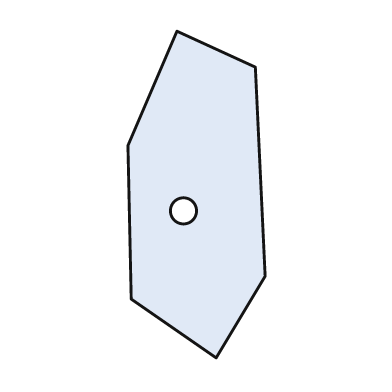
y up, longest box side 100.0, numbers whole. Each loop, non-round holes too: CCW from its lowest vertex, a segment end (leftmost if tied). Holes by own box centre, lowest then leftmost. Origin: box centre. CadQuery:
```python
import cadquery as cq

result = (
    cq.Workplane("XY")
    .moveTo(6.0, -50.0)
    .lineTo(21.0, -25.0)
    .lineTo(18.0, 39.0)
    .lineTo(-6.0, 50.0)
    .lineTo(-21.0, 15.0)
    .lineTo(-20.0, -32.0)
    .close()
    .moveTo(-4.0, -5.0)
    .circle(4.0)
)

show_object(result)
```